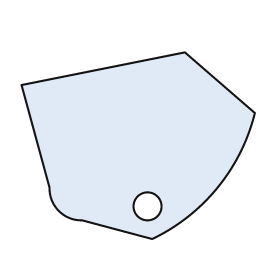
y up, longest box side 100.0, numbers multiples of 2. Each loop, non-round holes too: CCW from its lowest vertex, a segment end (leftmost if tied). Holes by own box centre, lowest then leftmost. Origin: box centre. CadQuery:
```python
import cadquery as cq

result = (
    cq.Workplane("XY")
    .moveTo(6.0, -40.0)
    .threePointArc((34.0, -18.0), (50.0, 14.0))
    .lineTo(20.0, 40.0)
    .lineTo(-50.0, 26.0)
    .lineTo(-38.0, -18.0)
    .threePointArc((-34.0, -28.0), (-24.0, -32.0))
    .close()
    .moveTo(4.0, -26.0)
    .circle(6.0)
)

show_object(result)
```